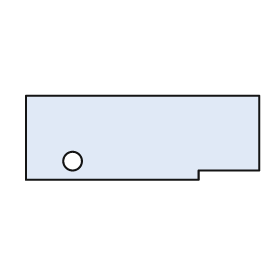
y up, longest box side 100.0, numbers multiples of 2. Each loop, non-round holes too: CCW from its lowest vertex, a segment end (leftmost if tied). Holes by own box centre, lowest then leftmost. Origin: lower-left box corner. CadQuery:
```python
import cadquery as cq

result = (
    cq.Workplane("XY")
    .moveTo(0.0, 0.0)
    .lineTo(74.0, 0.0)
    .lineTo(74.0, 4.0)
    .lineTo(100.0, 4.0)
    .lineTo(100.0, 36.0)
    .lineTo(0.0, 36.0)
    .close()
    .moveTo(20.0, 8.0)
    .circle(4.0)
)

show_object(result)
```